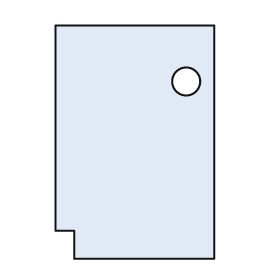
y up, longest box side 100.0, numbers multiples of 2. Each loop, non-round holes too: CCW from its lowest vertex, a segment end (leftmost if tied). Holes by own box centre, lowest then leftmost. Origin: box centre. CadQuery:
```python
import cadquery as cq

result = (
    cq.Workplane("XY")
    .moveTo(-26.0, -50.0)
    .lineTo(34.0, -50.0)
    .lineTo(34.0, 50.0)
    .lineTo(-34.0, 50.0)
    .lineTo(-34.0, -38.0)
    .lineTo(-26.0, -38.0)
    .close()
    .moveTo(22.0, 26.0)
    .circle(6.0)
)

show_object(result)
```